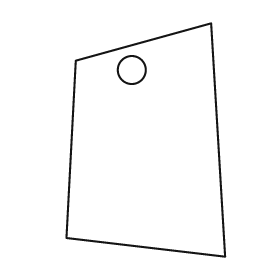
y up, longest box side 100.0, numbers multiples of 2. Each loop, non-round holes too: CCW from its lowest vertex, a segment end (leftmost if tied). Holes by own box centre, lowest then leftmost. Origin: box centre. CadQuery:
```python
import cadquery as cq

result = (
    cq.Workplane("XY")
    .moveTo(34.0, -50.0)
    .lineTo(28.0, 50.0)
    .lineTo(-30.0, 34.0)
    .lineTo(-34.0, -42.0)
    .close()
    .moveTo(-6.0, 30.0)
    .circle(6.0)
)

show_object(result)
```